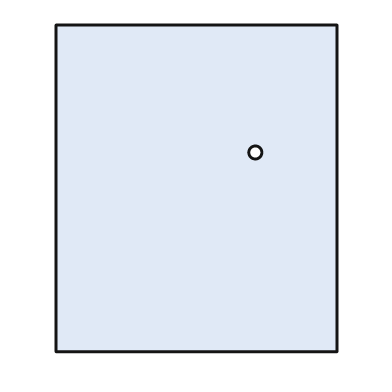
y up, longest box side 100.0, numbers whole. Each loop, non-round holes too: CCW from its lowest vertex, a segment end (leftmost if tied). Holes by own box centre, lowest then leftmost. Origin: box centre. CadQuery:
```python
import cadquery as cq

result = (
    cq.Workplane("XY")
    .moveTo(-43.0, -50.0)
    .lineTo(43.0, -50.0)
    .lineTo(43.0, 50.0)
    .lineTo(-43.0, 50.0)
    .close()
    .moveTo(18.0, 11.0)
    .circle(2.0)
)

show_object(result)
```